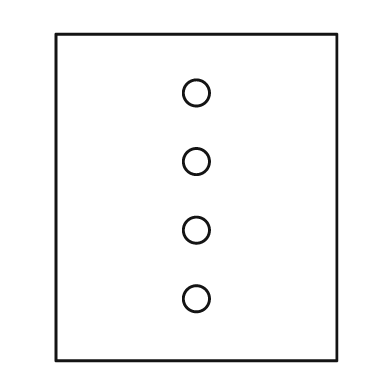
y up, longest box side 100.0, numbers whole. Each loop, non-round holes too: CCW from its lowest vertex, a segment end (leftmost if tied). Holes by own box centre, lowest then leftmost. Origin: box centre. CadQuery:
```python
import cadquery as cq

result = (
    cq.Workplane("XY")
    .moveTo(-43.0, -50.0)
    .lineTo(43.0, -50.0)
    .lineTo(43.0, 50.0)
    .lineTo(-43.0, 50.0)
    .close()
    .moveTo(0.0, -31.0)
    .circle(4.0)
    .moveTo(0.0, -10.0)
    .circle(4.0)
    .moveTo(0.0, 11.0)
    .circle(4.0)
    .moveTo(0.0, 32.0)
    .circle(4.0)
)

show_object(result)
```